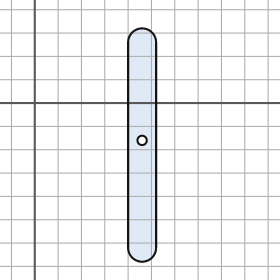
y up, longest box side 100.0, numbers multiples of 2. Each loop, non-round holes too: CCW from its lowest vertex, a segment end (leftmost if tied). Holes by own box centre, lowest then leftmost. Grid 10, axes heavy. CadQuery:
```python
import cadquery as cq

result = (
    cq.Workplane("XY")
    .moveTo(40.0, -62.0)
    .threePointArc((46.0, -68.0), (52.0, -62.0))
    .lineTo(52.0, 26.0)
    .threePointArc((46.0, 32.0), (40.0, 26.0))
    .close()
    .moveTo(46.0, -16.0)
    .circle(2.0)
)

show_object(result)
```